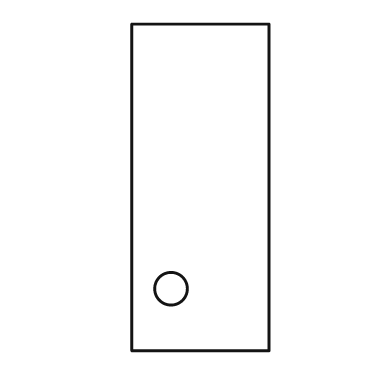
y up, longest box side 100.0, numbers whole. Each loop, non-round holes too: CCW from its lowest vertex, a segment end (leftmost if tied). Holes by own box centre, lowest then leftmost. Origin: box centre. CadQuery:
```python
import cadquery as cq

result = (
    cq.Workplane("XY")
    .moveTo(-21.0, -50.0)
    .lineTo(21.0, -50.0)
    .lineTo(21.0, 50.0)
    .lineTo(-21.0, 50.0)
    .close()
    .moveTo(-9.0, -31.0)
    .circle(5.0)
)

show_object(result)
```